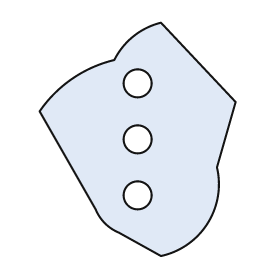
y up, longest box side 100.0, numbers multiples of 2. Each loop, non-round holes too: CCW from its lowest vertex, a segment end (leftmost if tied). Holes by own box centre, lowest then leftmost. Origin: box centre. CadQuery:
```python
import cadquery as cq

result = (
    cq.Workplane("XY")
    .moveTo(10.0, -50.0)
    .threePointArc((30.0, -36.0), (34.0, -12.0))
    .lineTo(42.0, 16.0)
    .lineTo(10.0, 50.0)
    .threePointArc((-2.0, 44.0), (-10.0, 34.0))
    .threePointArc((-28.0, 26.0), (-42.0, 12.0))
    .lineTo(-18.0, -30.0)
    .threePointArc((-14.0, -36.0), (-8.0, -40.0))
    .close()
    .moveTo(0.0, -24.0)
    .circle(6.0)
    .moveTo(0.0, 0.0)
    .circle(6.0)
    .moveTo(0.0, 24.0)
    .circle(6.0)
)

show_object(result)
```